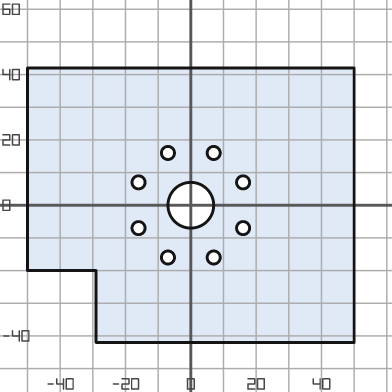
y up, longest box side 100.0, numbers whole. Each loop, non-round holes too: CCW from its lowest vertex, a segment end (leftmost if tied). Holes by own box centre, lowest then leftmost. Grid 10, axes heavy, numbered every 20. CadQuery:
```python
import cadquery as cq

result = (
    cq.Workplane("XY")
    .moveTo(-29.0, -42.0)
    .lineTo(50.0, -42.0)
    .lineTo(50.0, 42.0)
    .lineTo(-50.0, 42.0)
    .lineTo(-50.0, -20.0)
    .lineTo(-29.0, -20.0)
    .close()
    .moveTo(-7.0, -16.0)
    .circle(2.0)
    .moveTo(7.0, -16.0)
    .circle(2.0)
    .moveTo(-16.0, -7.0)
    .circle(2.0)
    .moveTo(16.0, -7.0)
    .circle(2.0)
    .moveTo(0.0, 0.0)
    .circle(7.0)
    .moveTo(-16.0, 7.0)
    .circle(2.0)
    .moveTo(16.0, 7.0)
    .circle(2.0)
    .moveTo(-7.0, 16.0)
    .circle(2.0)
    .moveTo(7.0, 16.0)
    .circle(2.0)
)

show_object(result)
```